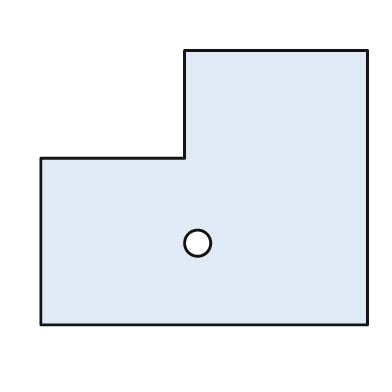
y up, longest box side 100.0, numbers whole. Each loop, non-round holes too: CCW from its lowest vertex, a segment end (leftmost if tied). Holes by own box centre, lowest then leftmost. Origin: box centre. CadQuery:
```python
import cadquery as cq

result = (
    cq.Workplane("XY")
    .moveTo(-50.0, -42.0)
    .lineTo(50.0, -42.0)
    .lineTo(50.0, 42.0)
    .lineTo(-6.0, 42.0)
    .lineTo(-6.0, 9.0)
    .lineTo(-50.0, 9.0)
    .close()
    .moveTo(-2.0, -17.0)
    .circle(4.0)
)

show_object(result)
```